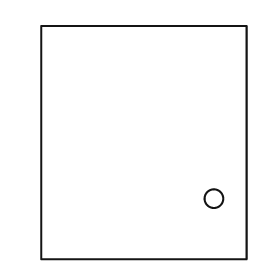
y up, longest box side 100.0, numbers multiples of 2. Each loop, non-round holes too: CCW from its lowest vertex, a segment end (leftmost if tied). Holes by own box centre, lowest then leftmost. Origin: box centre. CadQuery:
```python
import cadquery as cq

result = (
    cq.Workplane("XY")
    .moveTo(-44.0, -50.0)
    .lineTo(44.0, -50.0)
    .lineTo(44.0, 50.0)
    .lineTo(-44.0, 50.0)
    .close()
    .moveTo(30.0, -24.0)
    .circle(4.0)
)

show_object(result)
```